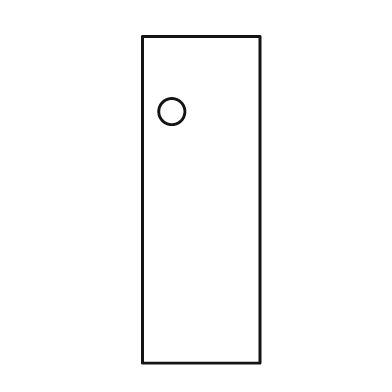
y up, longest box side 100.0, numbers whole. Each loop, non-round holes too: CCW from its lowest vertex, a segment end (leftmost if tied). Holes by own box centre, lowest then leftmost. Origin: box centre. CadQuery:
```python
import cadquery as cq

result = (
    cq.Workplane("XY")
    .moveTo(-18.0, -50.0)
    .lineTo(18.0, -50.0)
    .lineTo(18.0, 50.0)
    .lineTo(-18.0, 50.0)
    .close()
    .moveTo(-9.0, 27.0)
    .circle(4.0)
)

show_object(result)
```